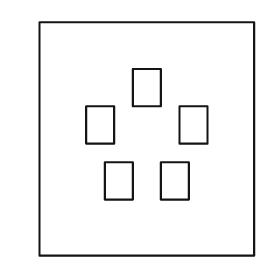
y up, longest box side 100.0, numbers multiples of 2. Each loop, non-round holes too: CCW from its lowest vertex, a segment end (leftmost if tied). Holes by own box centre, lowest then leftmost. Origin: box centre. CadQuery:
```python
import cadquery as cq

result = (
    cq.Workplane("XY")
    .moveTo(-46.0, -50.0)
    .lineTo(46.0, -50.0)
    .lineTo(46.0, 50.0)
    .lineTo(-46.0, 50.0)
    .close()
    .moveTo(-18.0, -26.0)
    .lineTo(-6.0, -26.0)
    .lineTo(-6.0, -10.0)
    .lineTo(-18.0, -10.0)
    .close()
    .moveTo(6.0, -26.0)
    .lineTo(18.0, -26.0)
    .lineTo(18.0, -10.0)
    .lineTo(6.0, -10.0)
    .close()
    .moveTo(-26.0, -2.0)
    .lineTo(-14.0, -2.0)
    .lineTo(-14.0, 14.0)
    .lineTo(-26.0, 14.0)
    .close()
    .moveTo(14.0, -2.0)
    .lineTo(26.0, -2.0)
    .lineTo(26.0, 14.0)
    .lineTo(14.0, 14.0)
    .close()
    .moveTo(-6.0, 14.0)
    .lineTo(6.0, 14.0)
    .lineTo(6.0, 30.0)
    .lineTo(-6.0, 30.0)
    .close()
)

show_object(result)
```